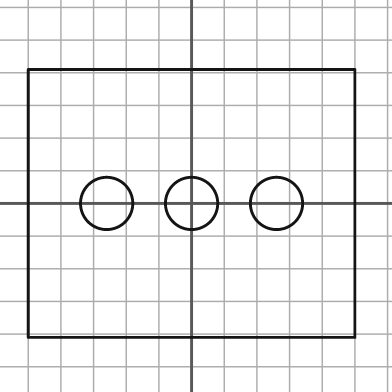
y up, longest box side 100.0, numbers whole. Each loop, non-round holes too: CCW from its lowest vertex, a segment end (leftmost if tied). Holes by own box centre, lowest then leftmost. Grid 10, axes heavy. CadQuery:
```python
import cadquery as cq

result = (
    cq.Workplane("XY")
    .moveTo(-50.0, -41.0)
    .lineTo(50.0, -41.0)
    .lineTo(50.0, 41.0)
    .lineTo(-50.0, 41.0)
    .close()
    .moveTo(-26.0, 0.0)
    .circle(8.0)
    .moveTo(0.0, 0.0)
    .circle(8.0)
    .moveTo(26.0, 0.0)
    .circle(8.0)
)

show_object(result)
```